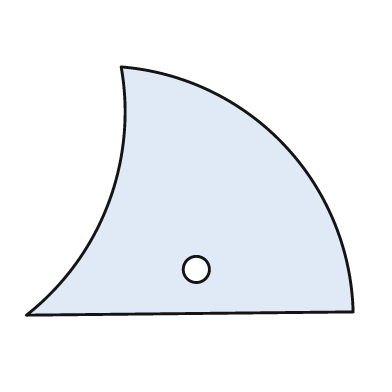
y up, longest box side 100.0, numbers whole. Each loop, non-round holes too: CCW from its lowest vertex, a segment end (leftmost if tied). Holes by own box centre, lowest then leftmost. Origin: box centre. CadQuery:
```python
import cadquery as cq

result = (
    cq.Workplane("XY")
    .moveTo(-50.0, -38.0)
    .lineTo(50.0, -37.0)
    .threePointArc((29.0, 14.0), (-21.0, 38.0))
    .threePointArc((-25.0, -4.0), (-50.0, -38.0))
    .close()
    .moveTo(2.0, -24.0)
    .circle(4.0)
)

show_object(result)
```